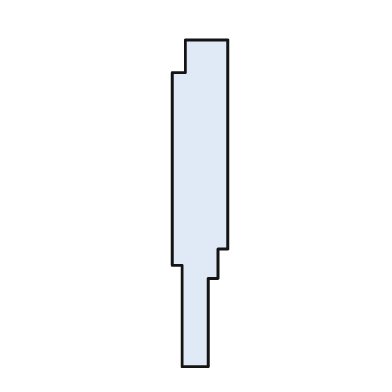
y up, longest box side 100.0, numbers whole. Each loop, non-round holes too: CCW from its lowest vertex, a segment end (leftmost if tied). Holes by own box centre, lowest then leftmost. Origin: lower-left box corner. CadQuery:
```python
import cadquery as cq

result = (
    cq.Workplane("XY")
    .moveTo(3.0, 0.0)
    .lineTo(11.0, 0.0)
    .lineTo(11.0, 27.0)
    .lineTo(14.0, 27.0)
    .lineTo(14.0, 36.0)
    .lineTo(17.0, 36.0)
    .lineTo(17.0, 100.0)
    .lineTo(4.0, 100.0)
    .lineTo(4.0, 90.0)
    .lineTo(0.0, 90.0)
    .lineTo(0.0, 31.0)
    .lineTo(3.0, 31.0)
    .close()
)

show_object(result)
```